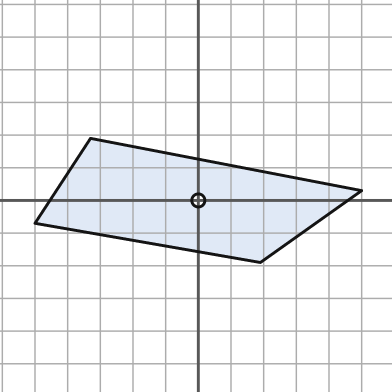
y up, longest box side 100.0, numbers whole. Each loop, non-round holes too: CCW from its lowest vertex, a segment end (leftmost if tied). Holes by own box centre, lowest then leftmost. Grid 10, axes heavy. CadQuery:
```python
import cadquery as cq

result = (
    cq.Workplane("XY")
    .moveTo(19.0, -19.0)
    .lineTo(50.0, 3.0)
    .lineTo(-33.0, 19.0)
    .lineTo(-50.0, -7.0)
    .close()
    .moveTo(0.0, 0.0)
    .circle(2.0)
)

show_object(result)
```